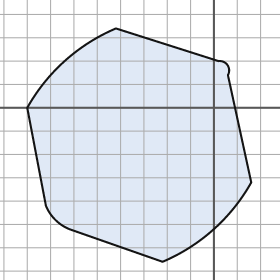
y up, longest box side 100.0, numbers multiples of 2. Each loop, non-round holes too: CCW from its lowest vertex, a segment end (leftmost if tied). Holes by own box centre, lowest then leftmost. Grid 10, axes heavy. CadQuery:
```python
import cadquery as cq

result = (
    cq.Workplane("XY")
    .moveTo(-22.0, -66.0)
    .threePointArc((0.0, -52.0), (16.0, -32.0))
    .lineTo(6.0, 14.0)
    .threePointArc((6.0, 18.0), (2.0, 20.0))
    .lineTo(-42.0, 34.0)
    .threePointArc((-64.0, 20.0), (-80.0, 0.0))
    .lineTo(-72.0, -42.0)
    .threePointArc((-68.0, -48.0), (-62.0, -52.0))
    .close()
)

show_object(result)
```